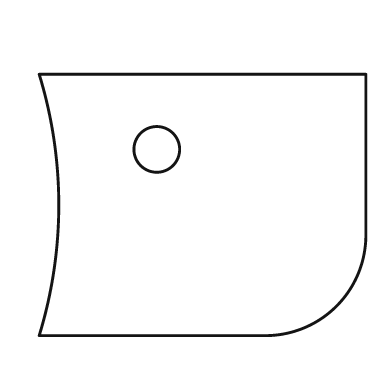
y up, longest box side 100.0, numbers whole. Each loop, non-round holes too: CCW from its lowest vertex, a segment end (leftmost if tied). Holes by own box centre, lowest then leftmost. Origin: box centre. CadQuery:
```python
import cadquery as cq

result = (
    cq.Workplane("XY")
    .moveTo(-50.0, -40.0)
    .lineTo(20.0, -40.0)
    .threePointArc((41.0, -31.0), (50.0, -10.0))
    .lineTo(50.0, 40.0)
    .lineTo(-50.0, 40.0)
    .threePointArc((-44.0, 0.0), (-50.0, -40.0))
    .close()
    .moveTo(-14.0, 17.0)
    .circle(7.0)
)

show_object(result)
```